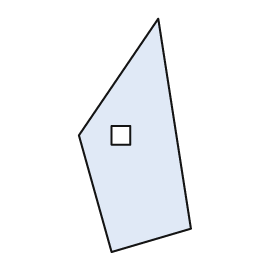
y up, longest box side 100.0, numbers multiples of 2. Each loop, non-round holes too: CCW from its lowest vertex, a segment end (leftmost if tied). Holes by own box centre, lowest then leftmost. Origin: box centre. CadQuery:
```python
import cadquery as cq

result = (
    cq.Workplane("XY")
    .moveTo(-10.0, -50.0)
    .lineTo(24.0, -40.0)
    .lineTo(10.0, 50.0)
    .lineTo(-24.0, 0.0)
    .close()
    .moveTo(-10.0, -4.0)
    .lineTo(-2.0, -4.0)
    .lineTo(-2.0, 4.0)
    .lineTo(-10.0, 4.0)
    .close()
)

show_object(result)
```